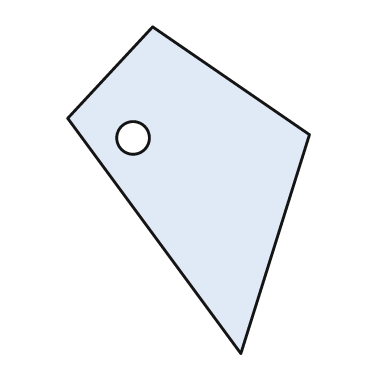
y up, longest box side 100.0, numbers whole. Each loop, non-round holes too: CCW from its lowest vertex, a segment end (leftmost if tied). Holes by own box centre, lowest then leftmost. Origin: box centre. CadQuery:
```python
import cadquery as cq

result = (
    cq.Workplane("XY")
    .moveTo(16.0, -50.0)
    .lineTo(37.0, 17.0)
    .lineTo(-11.0, 50.0)
    .lineTo(-37.0, 22.0)
    .close()
    .moveTo(-17.0, 16.0)
    .circle(5.0)
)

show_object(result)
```